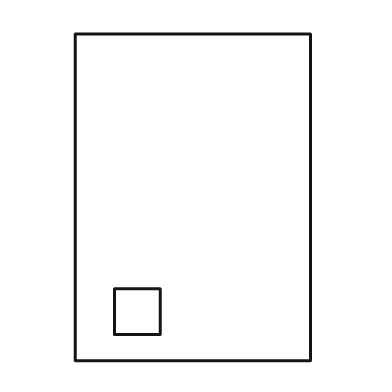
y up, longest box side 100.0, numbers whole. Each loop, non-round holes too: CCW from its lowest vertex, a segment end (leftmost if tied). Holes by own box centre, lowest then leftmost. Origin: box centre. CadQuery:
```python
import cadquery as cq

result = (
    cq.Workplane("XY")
    .moveTo(-36.0, -50.0)
    .lineTo(36.0, -50.0)
    .lineTo(36.0, 50.0)
    .lineTo(-36.0, 50.0)
    .close()
    .moveTo(-24.0, -42.0)
    .lineTo(-10.0, -42.0)
    .lineTo(-10.0, -28.0)
    .lineTo(-24.0, -28.0)
    .close()
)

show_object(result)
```